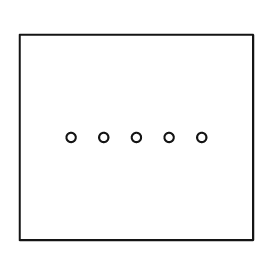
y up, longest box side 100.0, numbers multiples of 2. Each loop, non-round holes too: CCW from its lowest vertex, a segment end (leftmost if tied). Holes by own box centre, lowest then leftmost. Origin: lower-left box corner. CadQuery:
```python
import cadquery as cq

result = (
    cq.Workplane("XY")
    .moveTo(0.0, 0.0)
    .lineTo(100.0, 0.0)
    .lineTo(100.0, 88.0)
    .lineTo(0.0, 88.0)
    .close()
    .moveTo(22.0, 44.0)
    .circle(2.0)
    .moveTo(36.0, 44.0)
    .circle(2.0)
    .moveTo(50.0, 44.0)
    .circle(2.0)
    .moveTo(64.0, 44.0)
    .circle(2.0)
    .moveTo(78.0, 44.0)
    .circle(2.0)
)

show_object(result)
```